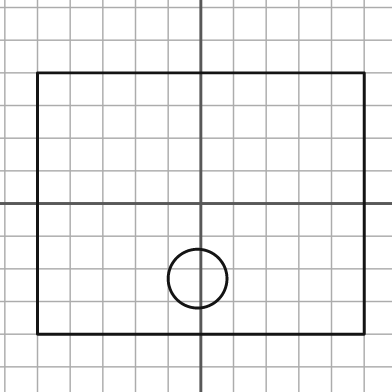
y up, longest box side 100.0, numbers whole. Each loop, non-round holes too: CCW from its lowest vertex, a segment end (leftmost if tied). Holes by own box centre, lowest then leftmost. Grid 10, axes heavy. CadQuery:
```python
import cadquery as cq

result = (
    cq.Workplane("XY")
    .moveTo(-50.0, -40.0)
    .lineTo(50.0, -40.0)
    .lineTo(50.0, 40.0)
    .lineTo(-50.0, 40.0)
    .close()
    .moveTo(-1.0, -23.0)
    .circle(9.0)
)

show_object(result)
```